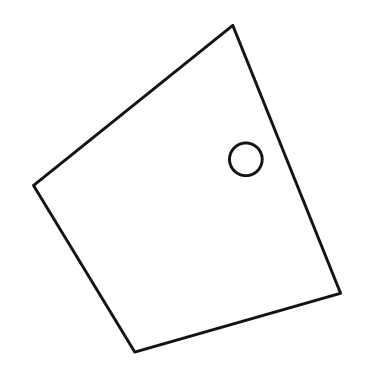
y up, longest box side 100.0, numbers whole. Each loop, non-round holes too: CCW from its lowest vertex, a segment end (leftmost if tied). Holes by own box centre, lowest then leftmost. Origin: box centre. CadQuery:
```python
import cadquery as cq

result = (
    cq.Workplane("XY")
    .moveTo(-16.0, -50.0)
    .lineTo(47.0, -32.0)
    .lineTo(14.0, 50.0)
    .lineTo(-47.0, 1.0)
    .close()
    .moveTo(18.0, 9.0)
    .circle(5.0)
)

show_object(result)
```